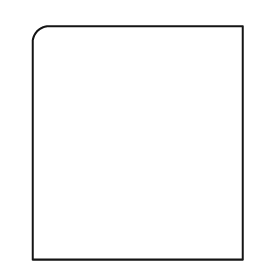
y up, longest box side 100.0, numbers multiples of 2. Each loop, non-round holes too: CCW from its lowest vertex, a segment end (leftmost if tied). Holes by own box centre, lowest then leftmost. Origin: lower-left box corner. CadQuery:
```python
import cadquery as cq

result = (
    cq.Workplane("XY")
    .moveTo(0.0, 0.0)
    .lineTo(90.0, 0.0)
    .lineTo(90.0, 100.0)
    .lineTo(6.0, 100.0)
    .threePointArc((2.0, 98.0), (0.0, 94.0))
    .close()
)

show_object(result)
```